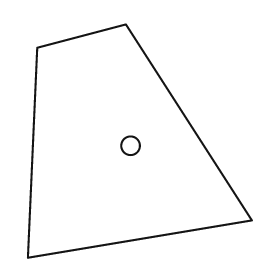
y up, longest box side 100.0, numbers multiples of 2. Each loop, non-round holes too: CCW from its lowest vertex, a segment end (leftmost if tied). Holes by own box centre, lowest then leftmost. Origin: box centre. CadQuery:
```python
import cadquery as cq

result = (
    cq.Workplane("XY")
    .moveTo(-48.0, -50.0)
    .lineTo(48.0, -34.0)
    .lineTo(-6.0, 50.0)
    .lineTo(-44.0, 40.0)
    .close()
    .moveTo(-4.0, -2.0)
    .circle(4.0)
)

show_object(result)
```